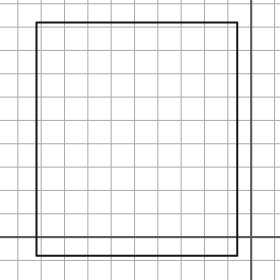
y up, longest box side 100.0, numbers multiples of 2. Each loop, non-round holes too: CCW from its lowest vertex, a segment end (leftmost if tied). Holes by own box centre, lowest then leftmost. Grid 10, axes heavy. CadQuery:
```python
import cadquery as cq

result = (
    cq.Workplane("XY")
    .moveTo(-92.0, -8.0)
    .lineTo(-6.0, -8.0)
    .lineTo(-6.0, 92.0)
    .lineTo(-92.0, 92.0)
    .close()
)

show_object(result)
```